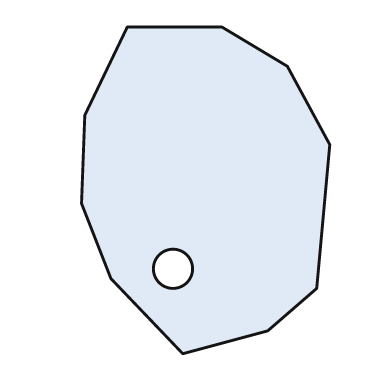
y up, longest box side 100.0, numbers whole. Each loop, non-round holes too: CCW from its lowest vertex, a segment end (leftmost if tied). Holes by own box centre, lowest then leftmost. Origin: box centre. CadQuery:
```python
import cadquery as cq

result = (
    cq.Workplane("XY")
    .moveTo(-7.0, -50.0)
    .lineTo(19.0, -43.0)
    .lineTo(34.0, -30.0)
    .lineTo(38.0, 14.0)
    .lineTo(25.0, 38.0)
    .lineTo(5.0, 50.0)
    .lineTo(-24.0, 50.0)
    .lineTo(-37.0, 23.0)
    .lineTo(-38.0, -4.0)
    .lineTo(-29.0, -27.0)
    .close()
    .moveTo(-10.0, -24.0)
    .circle(6.0)
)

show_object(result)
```